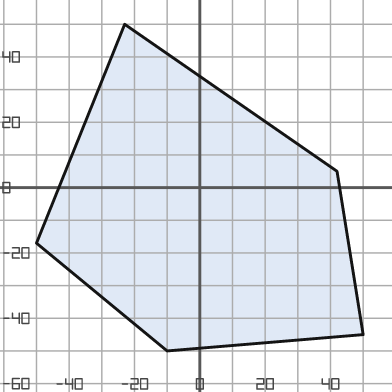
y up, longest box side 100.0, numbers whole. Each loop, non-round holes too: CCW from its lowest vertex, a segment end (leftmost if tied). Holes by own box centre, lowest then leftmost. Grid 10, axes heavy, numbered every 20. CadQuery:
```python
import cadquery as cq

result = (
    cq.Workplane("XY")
    .moveTo(-10.0, -50.0)
    .lineTo(50.0, -45.0)
    .lineTo(42.0, 5.0)
    .lineTo(-23.0, 50.0)
    .lineTo(-50.0, -17.0)
    .close()
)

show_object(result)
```